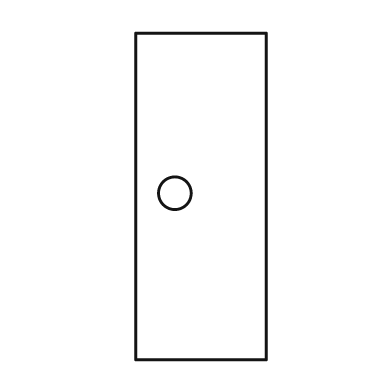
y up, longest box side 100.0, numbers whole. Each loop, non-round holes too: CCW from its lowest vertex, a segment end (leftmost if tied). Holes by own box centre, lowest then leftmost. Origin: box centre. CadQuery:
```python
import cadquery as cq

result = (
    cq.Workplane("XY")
    .moveTo(-20.0, -50.0)
    .lineTo(20.0, -50.0)
    .lineTo(20.0, 50.0)
    .lineTo(-20.0, 50.0)
    .close()
    .moveTo(-8.0, 1.0)
    .circle(5.0)
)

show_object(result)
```